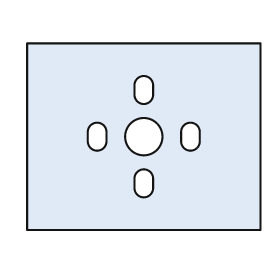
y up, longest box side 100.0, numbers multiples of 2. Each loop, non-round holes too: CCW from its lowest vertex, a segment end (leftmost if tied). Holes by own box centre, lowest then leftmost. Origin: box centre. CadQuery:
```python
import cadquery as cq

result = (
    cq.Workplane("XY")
    .moveTo(-50.0, -40.0)
    .lineTo(50.0, -40.0)
    .lineTo(50.0, 40.0)
    .lineTo(-50.0, 40.0)
    .close()
    .moveTo(-4.0, -22.0)
    .threePointArc((0.0, -26.0), (4.0, -22.0))
    .lineTo(4.0, -18.0)
    .threePointArc((0.0, -14.0), (-4.0, -18.0))
    .close()
    .moveTo(-24.0, -2.0)
    .threePointArc((-20.0, -6.0), (-16.0, -2.0))
    .lineTo(-16.0, 2.0)
    .threePointArc((-20.0, 6.0), (-24.0, 2.0))
    .close()
    .moveTo(0.0, 0.0)
    .circle(8.0)
    .moveTo(16.0, -2.0)
    .threePointArc((20.0, -6.0), (24.0, -2.0))
    .lineTo(24.0, 2.0)
    .threePointArc((20.0, 6.0), (16.0, 2.0))
    .close()
    .moveTo(-4.0, 18.0)
    .threePointArc((0.0, 14.0), (4.0, 18.0))
    .lineTo(4.0, 22.0)
    .threePointArc((0.0, 26.0), (-4.0, 22.0))
    .close()
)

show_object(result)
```